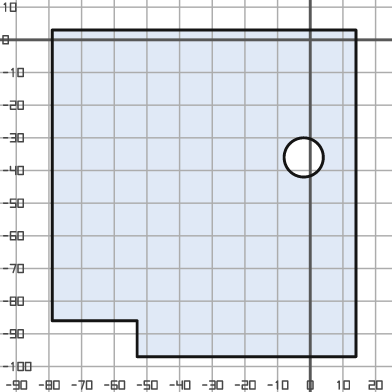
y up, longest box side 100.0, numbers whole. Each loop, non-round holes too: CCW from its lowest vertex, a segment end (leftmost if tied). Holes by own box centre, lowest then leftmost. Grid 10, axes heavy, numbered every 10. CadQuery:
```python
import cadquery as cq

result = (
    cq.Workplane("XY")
    .moveTo(-53.0, -97.0)
    .lineTo(14.0, -97.0)
    .lineTo(14.0, 3.0)
    .lineTo(-79.0, 3.0)
    .lineTo(-79.0, -86.0)
    .lineTo(-53.0, -86.0)
    .close()
    .moveTo(-2.0, -36.0)
    .circle(6.0)
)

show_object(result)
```